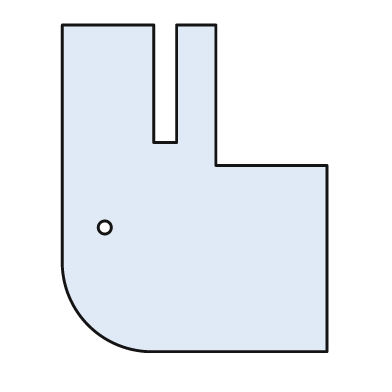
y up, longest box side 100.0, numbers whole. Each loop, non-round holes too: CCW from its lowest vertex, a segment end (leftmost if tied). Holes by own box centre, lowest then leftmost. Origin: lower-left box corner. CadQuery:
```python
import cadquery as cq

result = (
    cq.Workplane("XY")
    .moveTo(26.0, 0.0)
    .lineTo(81.0, 0.0)
    .lineTo(81.0, 57.0)
    .lineTo(47.0, 57.0)
    .lineTo(47.0, 100.0)
    .lineTo(35.0, 100.0)
    .lineTo(35.0, 64.0)
    .lineTo(28.0, 64.0)
    .lineTo(28.0, 100.0)
    .lineTo(0.0, 100.0)
    .lineTo(0.0, 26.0)
    .threePointArc((8.0, 8.0), (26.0, 0.0))
    .close()
    .moveTo(13.0, 38.0)
    .circle(2.0)
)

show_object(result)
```